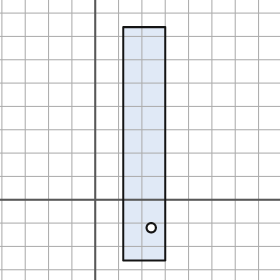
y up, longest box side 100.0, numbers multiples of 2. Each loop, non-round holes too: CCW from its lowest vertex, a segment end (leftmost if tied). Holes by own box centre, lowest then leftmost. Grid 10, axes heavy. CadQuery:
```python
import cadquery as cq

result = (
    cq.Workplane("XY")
    .moveTo(12.0, -26.0)
    .lineTo(30.0, -26.0)
    .lineTo(30.0, 74.0)
    .lineTo(12.0, 74.0)
    .close()
    .moveTo(24.0, -12.0)
    .circle(2.0)
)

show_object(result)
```